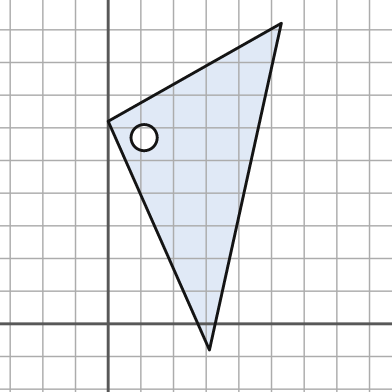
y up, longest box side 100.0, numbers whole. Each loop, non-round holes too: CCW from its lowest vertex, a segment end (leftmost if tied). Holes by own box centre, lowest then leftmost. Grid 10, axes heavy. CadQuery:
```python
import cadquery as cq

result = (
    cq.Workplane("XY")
    .moveTo(31.0, -8.0)
    .lineTo(53.0, 92.0)
    .lineTo(0.0, 62.0)
    .close()
    .moveTo(11.0, 57.0)
    .circle(4.0)
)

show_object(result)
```